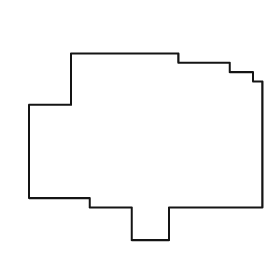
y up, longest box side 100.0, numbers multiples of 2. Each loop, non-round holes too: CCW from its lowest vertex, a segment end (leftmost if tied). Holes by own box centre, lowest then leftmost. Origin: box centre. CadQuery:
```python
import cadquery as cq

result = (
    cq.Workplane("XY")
    .moveTo(-6.0, -40.0)
    .lineTo(10.0, -40.0)
    .lineTo(10.0, -26.0)
    .lineTo(50.0, -26.0)
    .lineTo(50.0, 28.0)
    .lineTo(46.0, 28.0)
    .lineTo(46.0, 32.0)
    .lineTo(36.0, 32.0)
    .lineTo(36.0, 36.0)
    .lineTo(14.0, 36.0)
    .lineTo(14.0, 40.0)
    .lineTo(-32.0, 40.0)
    .lineTo(-32.0, 18.0)
    .lineTo(-50.0, 18.0)
    .lineTo(-50.0, -22.0)
    .lineTo(-24.0, -22.0)
    .lineTo(-24.0, -26.0)
    .lineTo(-6.0, -26.0)
    .close()
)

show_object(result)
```